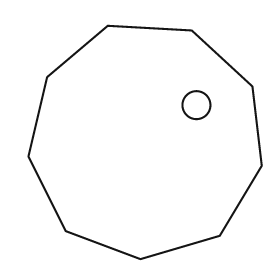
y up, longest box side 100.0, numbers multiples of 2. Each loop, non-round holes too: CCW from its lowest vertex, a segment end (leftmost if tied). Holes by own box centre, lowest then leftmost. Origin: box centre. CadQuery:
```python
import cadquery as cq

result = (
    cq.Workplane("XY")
    .moveTo(-2.0, -50.0)
    .lineTo(32.0, -40.0)
    .lineTo(50.0, -10.0)
    .lineTo(46.0, 24.0)
    .lineTo(20.0, 48.0)
    .lineTo(-16.0, 50.0)
    .lineTo(-42.0, 28.0)
    .lineTo(-50.0, -6.0)
    .lineTo(-34.0, -38.0)
    .close()
    .moveTo(22.0, 16.0)
    .circle(6.0)
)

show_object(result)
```